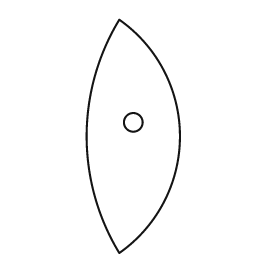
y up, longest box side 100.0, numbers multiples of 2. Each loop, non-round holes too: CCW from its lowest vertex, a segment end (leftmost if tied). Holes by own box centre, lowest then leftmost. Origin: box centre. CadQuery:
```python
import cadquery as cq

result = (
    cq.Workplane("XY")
    .moveTo(-6.0, -50.0)
    .threePointArc((20.0, 0.0), (-6.0, 50.0))
    .threePointArc((-20.0, 0.0), (-6.0, -50.0))
    .close()
    .moveTo(0.0, 6.0)
    .circle(4.0)
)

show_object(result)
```